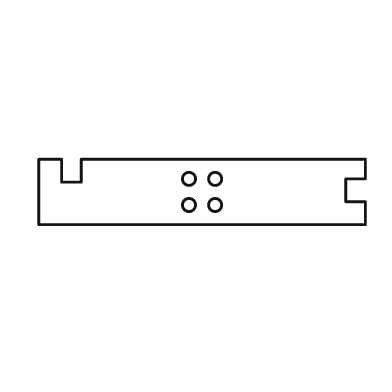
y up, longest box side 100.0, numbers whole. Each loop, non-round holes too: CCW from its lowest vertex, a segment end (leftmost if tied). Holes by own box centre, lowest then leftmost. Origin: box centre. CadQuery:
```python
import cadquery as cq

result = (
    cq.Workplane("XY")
    .moveTo(-50.0, -10.0)
    .lineTo(50.0, -10.0)
    .lineTo(50.0, -3.0)
    .lineTo(44.0, -3.0)
    .lineTo(44.0, 4.0)
    .lineTo(50.0, 4.0)
    .lineTo(50.0, 10.0)
    .lineTo(-37.0, 10.0)
    .lineTo(-37.0, 3.0)
    .lineTo(-43.0, 3.0)
    .lineTo(-43.0, 10.0)
    .lineTo(-50.0, 10.0)
    .close()
    .moveTo(-4.0, -4.0)
    .circle(2.0)
    .moveTo(4.0, -4.0)
    .circle(2.0)
    .moveTo(-4.0, 4.0)
    .circle(2.0)
    .moveTo(4.0, 4.0)
    .circle(2.0)
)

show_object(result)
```